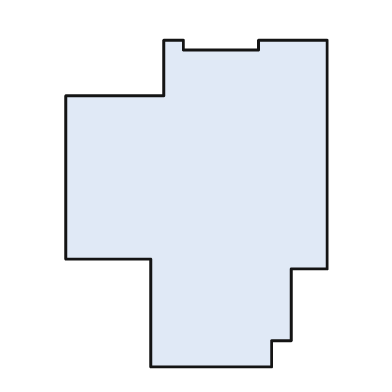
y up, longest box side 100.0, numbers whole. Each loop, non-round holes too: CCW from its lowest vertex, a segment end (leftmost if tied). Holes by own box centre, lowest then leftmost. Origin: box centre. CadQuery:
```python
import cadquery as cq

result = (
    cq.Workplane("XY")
    .moveTo(-14.0, -50.0)
    .lineTo(23.0, -50.0)
    .lineTo(23.0, -42.0)
    .lineTo(29.0, -42.0)
    .lineTo(29.0, -20.0)
    .lineTo(40.0, -20.0)
    .lineTo(40.0, 50.0)
    .lineTo(19.0, 50.0)
    .lineTo(19.0, 47.0)
    .lineTo(-4.0, 47.0)
    .lineTo(-4.0, 50.0)
    .lineTo(-10.0, 50.0)
    .lineTo(-10.0, 33.0)
    .lineTo(-40.0, 33.0)
    .lineTo(-40.0, -17.0)
    .lineTo(-14.0, -17.0)
    .close()
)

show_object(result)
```